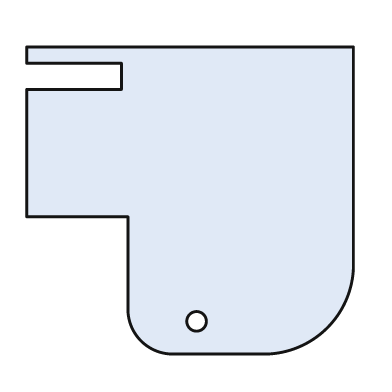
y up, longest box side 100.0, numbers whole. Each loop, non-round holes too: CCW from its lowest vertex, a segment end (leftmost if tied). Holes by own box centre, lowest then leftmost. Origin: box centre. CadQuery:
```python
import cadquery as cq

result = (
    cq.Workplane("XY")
    .moveTo(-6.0, -47.0)
    .lineTo(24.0, -47.0)
    .threePointArc((42.0, -39.0), (50.0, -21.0))
    .lineTo(50.0, 47.0)
    .lineTo(-50.0, 47.0)
    .lineTo(-50.0, 42.0)
    .lineTo(-21.0, 42.0)
    .lineTo(-21.0, 34.0)
    .lineTo(-50.0, 34.0)
    .lineTo(-50.0, -5.0)
    .lineTo(-19.0, -5.0)
    .lineTo(-19.0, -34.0)
    .threePointArc((-15.0, -43.0), (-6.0, -47.0))
    .close()
    .moveTo(2.0, -37.0)
    .circle(3.0)
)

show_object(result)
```